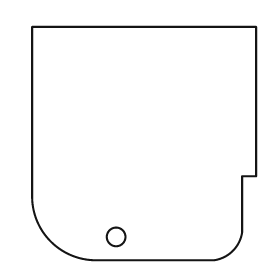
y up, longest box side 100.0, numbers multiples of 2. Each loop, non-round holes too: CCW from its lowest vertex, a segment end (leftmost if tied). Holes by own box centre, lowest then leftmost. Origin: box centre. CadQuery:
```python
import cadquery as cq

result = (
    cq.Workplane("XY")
    .moveTo(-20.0, -50.0)
    .lineTo(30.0, -50.0)
    .threePointArc((38.0, -46.0), (42.0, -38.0))
    .lineTo(42.0, -14.0)
    .lineTo(48.0, -14.0)
    .lineTo(48.0, 50.0)
    .lineTo(-48.0, 50.0)
    .lineTo(-48.0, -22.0)
    .threePointArc((-40.0, -42.0), (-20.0, -50.0))
    .close()
    .moveTo(-12.0, -40.0)
    .circle(4.0)
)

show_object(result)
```